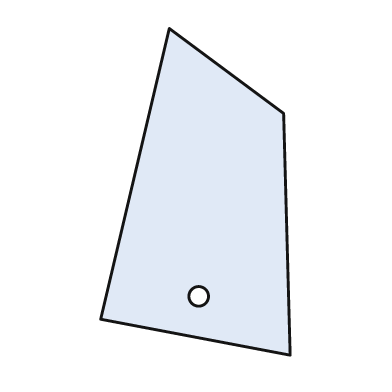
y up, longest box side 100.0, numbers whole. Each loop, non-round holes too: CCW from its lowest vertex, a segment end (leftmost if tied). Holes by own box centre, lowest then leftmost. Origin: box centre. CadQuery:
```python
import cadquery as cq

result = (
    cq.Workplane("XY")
    .moveTo(29.0, -50.0)
    .lineTo(27.0, 24.0)
    .lineTo(-8.0, 50.0)
    .lineTo(-29.0, -39.0)
    .close()
    .moveTo(1.0, -32.0)
    .circle(3.0)
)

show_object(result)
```